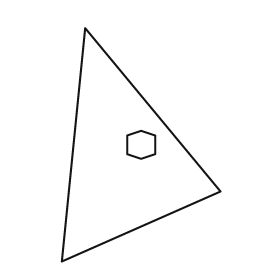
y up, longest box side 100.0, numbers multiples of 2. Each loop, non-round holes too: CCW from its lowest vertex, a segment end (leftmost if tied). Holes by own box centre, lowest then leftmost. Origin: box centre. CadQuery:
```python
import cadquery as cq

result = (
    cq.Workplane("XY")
    .moveTo(-34.0, -50.0)
    .lineTo(34.0, -20.0)
    .lineTo(-24.0, 50.0)
    .close()
    .moveTo(0.0, -6.0)
    .lineTo(6.0, -4.0)
    .lineTo(6.0, 4.0)
    .lineTo(0.0, 6.0)
    .lineTo(-6.0, 4.0)
    .lineTo(-6.0, -4.0)
    .close()
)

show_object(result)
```